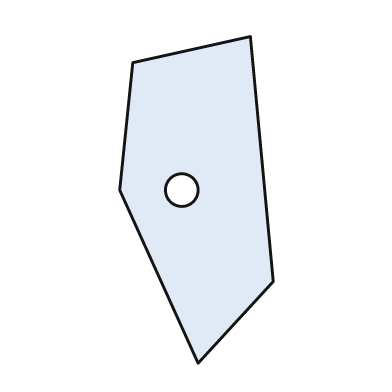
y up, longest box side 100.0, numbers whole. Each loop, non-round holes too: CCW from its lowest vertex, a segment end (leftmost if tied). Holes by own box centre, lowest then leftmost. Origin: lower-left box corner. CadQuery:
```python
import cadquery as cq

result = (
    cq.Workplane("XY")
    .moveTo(24.0, 0.0)
    .lineTo(47.0, 25.0)
    .lineTo(40.0, 100.0)
    .lineTo(4.0, 92.0)
    .lineTo(0.0, 53.0)
    .close()
    .moveTo(19.0, 53.0)
    .circle(5.0)
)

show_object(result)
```